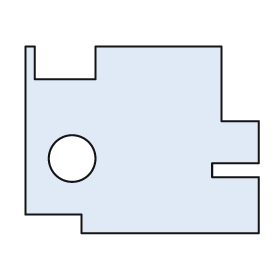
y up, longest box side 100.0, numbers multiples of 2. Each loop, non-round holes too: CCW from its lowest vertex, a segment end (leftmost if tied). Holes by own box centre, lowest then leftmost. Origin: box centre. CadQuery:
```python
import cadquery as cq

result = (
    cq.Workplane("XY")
    .moveTo(-26.0, -40.0)
    .lineTo(50.0, -40.0)
    .lineTo(50.0, -16.0)
    .lineTo(30.0, -16.0)
    .lineTo(30.0, -10.0)
    .lineTo(50.0, -10.0)
    .lineTo(50.0, 8.0)
    .lineTo(34.0, 8.0)
    .lineTo(34.0, 40.0)
    .lineTo(-20.0, 40.0)
    .lineTo(-20.0, 26.0)
    .lineTo(-46.0, 26.0)
    .lineTo(-46.0, 40.0)
    .lineTo(-50.0, 40.0)
    .lineTo(-50.0, -32.0)
    .lineTo(-26.0, -32.0)
    .close()
    .moveTo(-30.0, -8.0)
    .circle(10.0)
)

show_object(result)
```